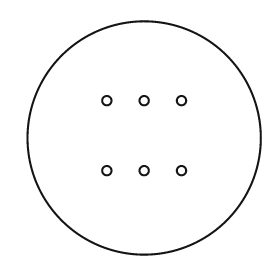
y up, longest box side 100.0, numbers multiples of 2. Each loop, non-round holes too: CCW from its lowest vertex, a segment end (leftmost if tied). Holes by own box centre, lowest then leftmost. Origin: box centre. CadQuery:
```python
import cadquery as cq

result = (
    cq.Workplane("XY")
    .moveTo(0.0, 0.0)
    .circle(50.0)
    .moveTo(-16.0, -14.0)
    .circle(2.0)
    .moveTo(0.0, -14.0)
    .circle(2.0)
    .moveTo(16.0, -14.0)
    .circle(2.0)
    .moveTo(-16.0, 16.0)
    .circle(2.0)
    .moveTo(0.0, 16.0)
    .circle(2.0)
    .moveTo(16.0, 16.0)
    .circle(2.0)
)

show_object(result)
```